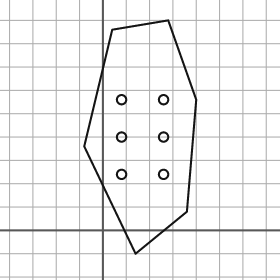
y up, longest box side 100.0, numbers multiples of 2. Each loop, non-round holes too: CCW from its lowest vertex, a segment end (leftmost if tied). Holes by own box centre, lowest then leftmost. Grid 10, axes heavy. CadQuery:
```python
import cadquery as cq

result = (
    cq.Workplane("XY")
    .moveTo(14.0, -10.0)
    .lineTo(36.0, 8.0)
    .lineTo(40.0, 56.0)
    .lineTo(28.0, 90.0)
    .lineTo(4.0, 86.0)
    .lineTo(-8.0, 36.0)
    .close()
    .moveTo(8.0, 24.0)
    .circle(2.0)
    .moveTo(26.0, 24.0)
    .circle(2.0)
    .moveTo(8.0, 40.0)
    .circle(2.0)
    .moveTo(26.0, 40.0)
    .circle(2.0)
    .moveTo(8.0, 56.0)
    .circle(2.0)
    .moveTo(26.0, 56.0)
    .circle(2.0)
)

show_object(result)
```